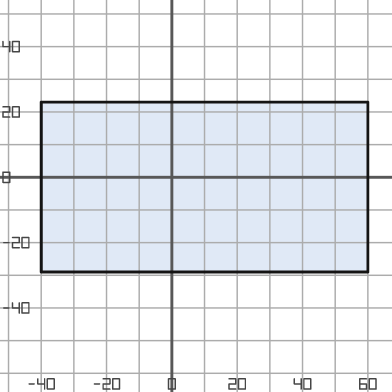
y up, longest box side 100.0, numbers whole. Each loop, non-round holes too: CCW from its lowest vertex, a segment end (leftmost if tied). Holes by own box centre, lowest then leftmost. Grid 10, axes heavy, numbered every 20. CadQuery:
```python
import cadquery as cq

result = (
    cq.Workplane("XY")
    .moveTo(-40.0, -29.0)
    .lineTo(60.0, -29.0)
    .lineTo(60.0, 23.0)
    .lineTo(-40.0, 23.0)
    .close()
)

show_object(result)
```